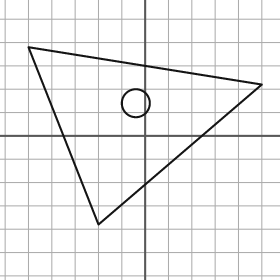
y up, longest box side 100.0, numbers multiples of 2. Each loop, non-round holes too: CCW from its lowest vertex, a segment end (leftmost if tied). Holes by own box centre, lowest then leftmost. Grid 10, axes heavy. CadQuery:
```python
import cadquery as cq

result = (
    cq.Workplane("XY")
    .moveTo(-20.0, -38.0)
    .lineTo(50.0, 22.0)
    .lineTo(-50.0, 38.0)
    .close()
    .moveTo(-4.0, 14.0)
    .circle(6.0)
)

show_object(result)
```